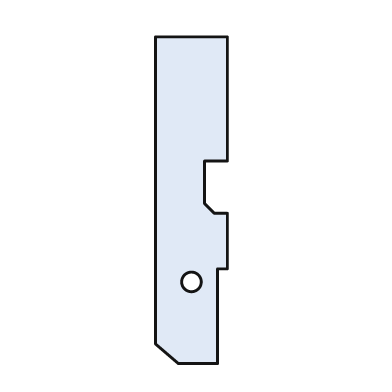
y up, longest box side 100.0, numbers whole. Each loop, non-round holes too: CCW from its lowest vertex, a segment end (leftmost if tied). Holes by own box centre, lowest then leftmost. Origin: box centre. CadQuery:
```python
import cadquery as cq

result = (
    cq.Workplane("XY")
    .moveTo(-4.0, -50.0)
    .lineTo(8.0, -50.0)
    .lineTo(8.0, -21.0)
    .lineTo(11.0, -21.0)
    .lineTo(11.0, -4.0)
    .lineTo(7.0, -4.0)
    .lineTo(4.0, -1.0)
    .lineTo(4.0, 12.0)
    .lineTo(11.0, 12.0)
    .lineTo(11.0, 50.0)
    .lineTo(-11.0, 50.0)
    .lineTo(-11.0, -44.0)
    .close()
    .moveTo(0.0, -25.0)
    .circle(3.0)
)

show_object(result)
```